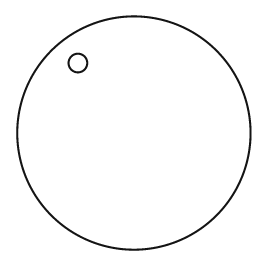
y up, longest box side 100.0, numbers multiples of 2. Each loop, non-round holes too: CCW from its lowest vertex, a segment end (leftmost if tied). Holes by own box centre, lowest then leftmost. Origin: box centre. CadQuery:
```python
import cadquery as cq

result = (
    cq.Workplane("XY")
    .moveTo(0.0, 0.0)
    .circle(50.0)
    .moveTo(-24.0, 30.0)
    .circle(4.0)
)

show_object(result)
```